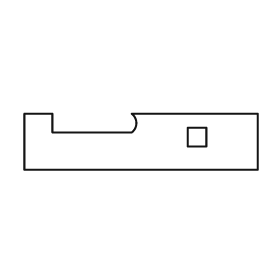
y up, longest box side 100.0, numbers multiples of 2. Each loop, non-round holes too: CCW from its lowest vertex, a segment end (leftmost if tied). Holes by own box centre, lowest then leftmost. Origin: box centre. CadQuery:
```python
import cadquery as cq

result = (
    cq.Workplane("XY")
    .moveTo(-50.0, -12.0)
    .lineTo(50.0, -12.0)
    .lineTo(50.0, 12.0)
    .lineTo(-4.0, 12.0)
    .threePointArc((-2.0, 8.0), (-4.0, 4.0))
    .lineTo(-38.0, 4.0)
    .lineTo(-38.0, 12.0)
    .lineTo(-50.0, 12.0)
    .close()
    .moveTo(20.0, -2.0)
    .lineTo(28.0, -2.0)
    .lineTo(28.0, 6.0)
    .lineTo(20.0, 6.0)
    .close()
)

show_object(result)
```